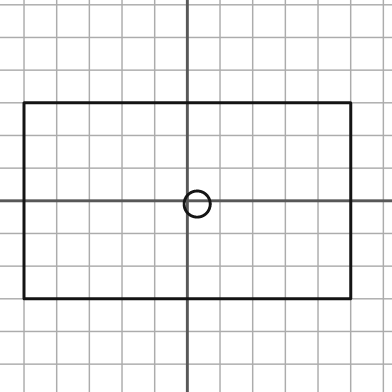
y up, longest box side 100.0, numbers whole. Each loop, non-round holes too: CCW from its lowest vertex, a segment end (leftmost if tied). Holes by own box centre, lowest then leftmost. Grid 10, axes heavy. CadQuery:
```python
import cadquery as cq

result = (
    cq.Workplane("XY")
    .moveTo(-50.0, -30.0)
    .lineTo(50.0, -30.0)
    .lineTo(50.0, 30.0)
    .lineTo(-50.0, 30.0)
    .close()
    .moveTo(3.0, -1.0)
    .circle(4.0)
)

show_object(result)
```